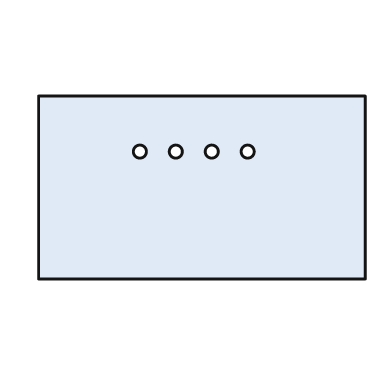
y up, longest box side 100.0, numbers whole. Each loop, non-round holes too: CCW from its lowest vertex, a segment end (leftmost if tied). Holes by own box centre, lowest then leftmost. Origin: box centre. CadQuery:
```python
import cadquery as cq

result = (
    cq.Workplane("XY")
    .moveTo(-50.0, -28.0)
    .lineTo(50.0, -28.0)
    .lineTo(50.0, 28.0)
    .lineTo(-50.0, 28.0)
    .close()
    .moveTo(-19.0, 11.0)
    .circle(2.0)
    .moveTo(-8.0, 11.0)
    .circle(2.0)
    .moveTo(3.0, 11.0)
    .circle(2.0)
    .moveTo(14.0, 11.0)
    .circle(2.0)
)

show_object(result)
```